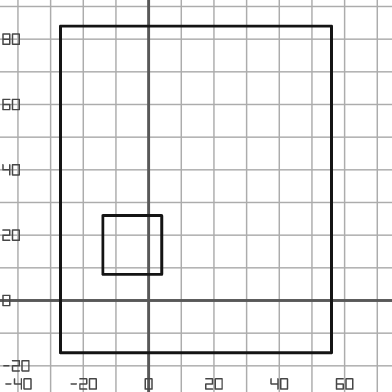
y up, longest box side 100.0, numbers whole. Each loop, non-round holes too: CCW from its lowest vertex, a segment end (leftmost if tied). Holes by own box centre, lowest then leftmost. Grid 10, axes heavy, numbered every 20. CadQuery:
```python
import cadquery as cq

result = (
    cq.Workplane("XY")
    .moveTo(-27.0, -16.0)
    .lineTo(56.0, -16.0)
    .lineTo(56.0, 84.0)
    .lineTo(-27.0, 84.0)
    .close()
    .moveTo(-14.0, 8.0)
    .lineTo(4.0, 8.0)
    .lineTo(4.0, 26.0)
    .lineTo(-14.0, 26.0)
    .close()
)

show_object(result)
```